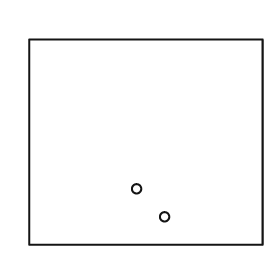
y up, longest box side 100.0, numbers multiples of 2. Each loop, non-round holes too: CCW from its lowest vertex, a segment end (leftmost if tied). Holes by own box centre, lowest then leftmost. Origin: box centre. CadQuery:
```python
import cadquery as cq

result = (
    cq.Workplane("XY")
    .moveTo(-50.0, -44.0)
    .lineTo(50.0, -44.0)
    .lineTo(50.0, 44.0)
    .lineTo(-50.0, 44.0)
    .close()
    .moveTo(8.0, -32.0)
    .circle(2.0)
    .moveTo(-4.0, -20.0)
    .circle(2.0)
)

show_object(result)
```